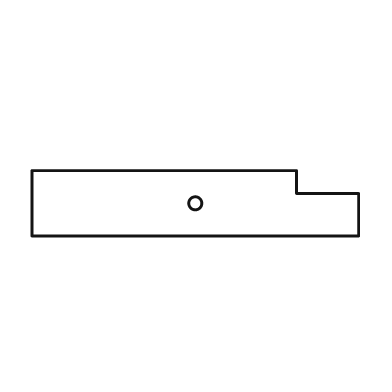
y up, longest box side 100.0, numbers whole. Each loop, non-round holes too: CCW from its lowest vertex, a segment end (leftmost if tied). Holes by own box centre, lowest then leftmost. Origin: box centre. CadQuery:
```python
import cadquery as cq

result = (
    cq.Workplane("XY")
    .moveTo(-50.0, -10.0)
    .lineTo(50.0, -10.0)
    .lineTo(50.0, 3.0)
    .lineTo(31.0, 3.0)
    .lineTo(31.0, 10.0)
    .lineTo(-50.0, 10.0)
    .close()
    .moveTo(0.0, 0.0)
    .circle(2.0)
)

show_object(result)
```